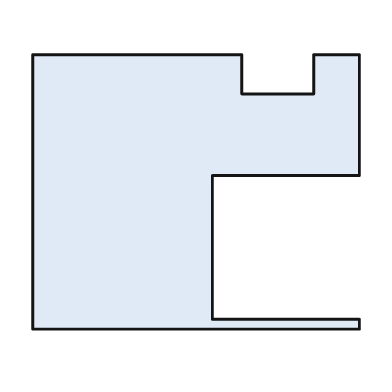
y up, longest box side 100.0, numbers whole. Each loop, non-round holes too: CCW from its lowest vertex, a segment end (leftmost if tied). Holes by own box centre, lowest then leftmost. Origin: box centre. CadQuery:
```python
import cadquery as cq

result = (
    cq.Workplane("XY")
    .moveTo(-50.0, -42.0)
    .lineTo(50.0, -42.0)
    .lineTo(50.0, -39.0)
    .lineTo(5.0, -39.0)
    .lineTo(5.0, 5.0)
    .lineTo(50.0, 5.0)
    .lineTo(50.0, 42.0)
    .lineTo(36.0, 42.0)
    .lineTo(36.0, 30.0)
    .lineTo(14.0, 30.0)
    .lineTo(14.0, 42.0)
    .lineTo(-50.0, 42.0)
    .close()
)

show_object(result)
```